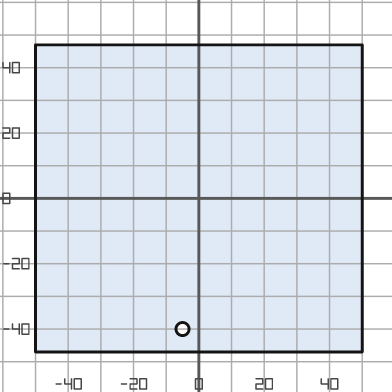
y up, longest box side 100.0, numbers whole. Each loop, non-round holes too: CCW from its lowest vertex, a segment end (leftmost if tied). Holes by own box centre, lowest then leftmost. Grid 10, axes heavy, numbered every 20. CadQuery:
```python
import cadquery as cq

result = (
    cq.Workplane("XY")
    .moveTo(-50.0, -47.0)
    .lineTo(50.0, -47.0)
    .lineTo(50.0, 47.0)
    .lineTo(-50.0, 47.0)
    .close()
    .moveTo(-5.0, -40.0)
    .circle(2.0)
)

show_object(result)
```